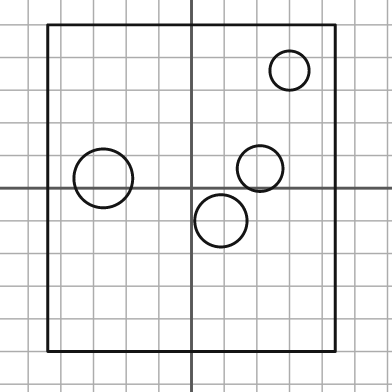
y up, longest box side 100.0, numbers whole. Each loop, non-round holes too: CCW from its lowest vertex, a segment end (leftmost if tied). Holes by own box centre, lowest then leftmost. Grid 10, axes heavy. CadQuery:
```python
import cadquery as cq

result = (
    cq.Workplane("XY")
    .moveTo(-44.0, -50.0)
    .lineTo(44.0, -50.0)
    .lineTo(44.0, 50.0)
    .lineTo(-44.0, 50.0)
    .close()
    .moveTo(9.0, -10.0)
    .circle(8.0)
    .moveTo(-27.0, 3.0)
    .circle(9.0)
    .moveTo(21.0, 6.0)
    .circle(7.0)
    .moveTo(30.0, 36.0)
    .circle(6.0)
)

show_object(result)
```